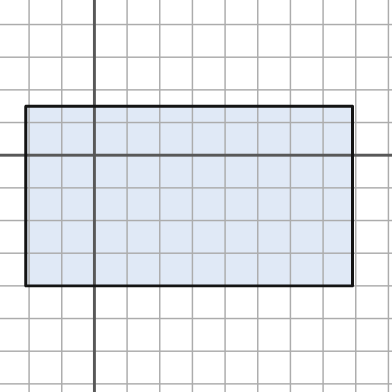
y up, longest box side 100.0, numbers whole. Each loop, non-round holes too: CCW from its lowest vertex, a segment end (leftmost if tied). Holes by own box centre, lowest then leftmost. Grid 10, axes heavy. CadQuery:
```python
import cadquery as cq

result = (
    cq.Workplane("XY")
    .moveTo(-21.0, -40.0)
    .lineTo(79.0, -40.0)
    .lineTo(79.0, 15.0)
    .lineTo(-21.0, 15.0)
    .close()
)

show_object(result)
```